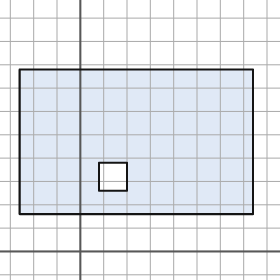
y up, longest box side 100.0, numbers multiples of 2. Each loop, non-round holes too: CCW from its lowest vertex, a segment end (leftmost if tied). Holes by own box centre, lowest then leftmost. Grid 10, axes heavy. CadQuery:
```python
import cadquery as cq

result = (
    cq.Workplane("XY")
    .moveTo(-26.0, 16.0)
    .lineTo(74.0, 16.0)
    .lineTo(74.0, 78.0)
    .lineTo(-26.0, 78.0)
    .close()
    .moveTo(8.0, 26.0)
    .lineTo(20.0, 26.0)
    .lineTo(20.0, 38.0)
    .lineTo(8.0, 38.0)
    .close()
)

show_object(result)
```